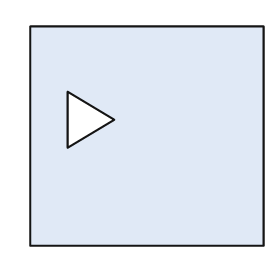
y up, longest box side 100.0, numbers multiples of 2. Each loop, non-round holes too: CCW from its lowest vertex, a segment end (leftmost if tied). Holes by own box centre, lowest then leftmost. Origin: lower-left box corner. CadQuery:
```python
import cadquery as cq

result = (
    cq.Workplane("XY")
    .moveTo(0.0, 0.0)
    .lineTo(100.0, 0.0)
    .lineTo(100.0, 94.0)
    .lineTo(0.0, 94.0)
    .close()
    .moveTo(16.0, 42.0)
    .lineTo(36.0, 54.0)
    .lineTo(16.0, 66.0)
    .close()
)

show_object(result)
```